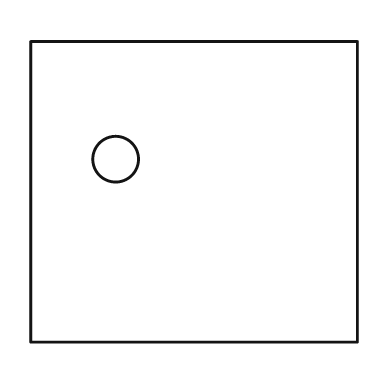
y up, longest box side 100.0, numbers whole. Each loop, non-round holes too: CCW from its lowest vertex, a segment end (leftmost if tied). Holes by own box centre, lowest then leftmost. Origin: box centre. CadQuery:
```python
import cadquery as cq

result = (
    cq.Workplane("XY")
    .moveTo(-50.0, -46.0)
    .lineTo(50.0, -46.0)
    .lineTo(50.0, 46.0)
    .lineTo(-50.0, 46.0)
    .close()
    .moveTo(-24.0, 10.0)
    .circle(7.0)
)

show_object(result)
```